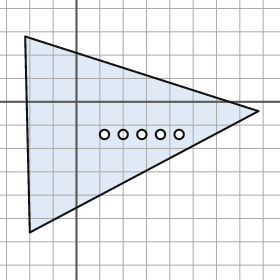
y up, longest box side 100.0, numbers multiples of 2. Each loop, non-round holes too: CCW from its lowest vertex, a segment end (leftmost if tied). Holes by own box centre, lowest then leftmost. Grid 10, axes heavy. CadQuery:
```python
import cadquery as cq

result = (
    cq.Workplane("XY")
    .moveTo(-20.0, -56.0)
    .lineTo(78.0, -4.0)
    .lineTo(-22.0, 28.0)
    .close()
    .moveTo(12.0, -14.0)
    .circle(2.0)
    .moveTo(20.0, -14.0)
    .circle(2.0)
    .moveTo(28.0, -14.0)
    .circle(2.0)
    .moveTo(36.0, -14.0)
    .circle(2.0)
    .moveTo(44.0, -14.0)
    .circle(2.0)
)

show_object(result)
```